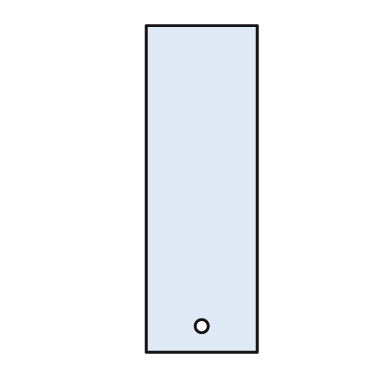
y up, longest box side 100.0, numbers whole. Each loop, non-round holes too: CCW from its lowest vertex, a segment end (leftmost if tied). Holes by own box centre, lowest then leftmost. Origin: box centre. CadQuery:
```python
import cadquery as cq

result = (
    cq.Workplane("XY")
    .moveTo(-17.0, -50.0)
    .lineTo(17.0, -50.0)
    .lineTo(17.0, 50.0)
    .lineTo(-17.0, 50.0)
    .close()
    .moveTo(0.0, -42.0)
    .circle(2.0)
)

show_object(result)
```